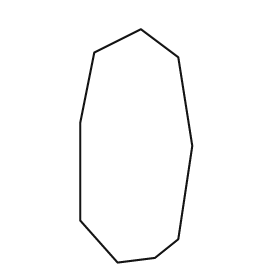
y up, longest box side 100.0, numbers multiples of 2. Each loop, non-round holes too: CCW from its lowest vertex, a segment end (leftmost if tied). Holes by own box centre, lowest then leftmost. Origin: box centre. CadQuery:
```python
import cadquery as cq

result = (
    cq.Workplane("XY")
    .moveTo(-8.0, -50.0)
    .lineTo(8.0, -48.0)
    .lineTo(18.0, -40.0)
    .lineTo(24.0, 0.0)
    .lineTo(18.0, 38.0)
    .lineTo(2.0, 50.0)
    .lineTo(-18.0, 40.0)
    .lineTo(-24.0, 10.0)
    .lineTo(-24.0, -32.0)
    .close()
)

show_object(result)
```